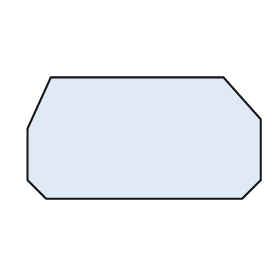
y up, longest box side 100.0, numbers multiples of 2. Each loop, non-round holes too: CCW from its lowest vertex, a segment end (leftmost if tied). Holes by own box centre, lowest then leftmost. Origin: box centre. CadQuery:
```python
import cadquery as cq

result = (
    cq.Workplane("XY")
    .moveTo(-42.0, -26.0)
    .lineTo(42.0, -26.0)
    .lineTo(50.0, -18.0)
    .lineTo(50.0, 8.0)
    .lineTo(34.0, 26.0)
    .lineTo(-40.0, 26.0)
    .lineTo(-50.0, 4.0)
    .lineTo(-50.0, -18.0)
    .close()
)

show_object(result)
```